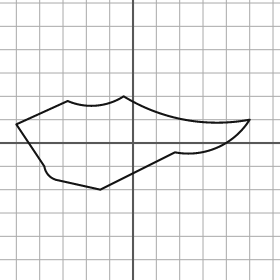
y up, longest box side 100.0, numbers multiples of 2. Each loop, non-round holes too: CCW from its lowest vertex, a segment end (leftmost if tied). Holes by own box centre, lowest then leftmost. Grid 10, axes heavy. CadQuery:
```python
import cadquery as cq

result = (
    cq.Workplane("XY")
    .moveTo(-14.0, -20.0)
    .lineTo(18.0, -4.0)
    .threePointArc((36.0, -2.0), (50.0, 10.0))
    .threePointArc((22.0, 10.0), (-4.0, 20.0))
    .threePointArc((-16.0, 16.0), (-28.0, 18.0))
    .lineTo(-50.0, 8.0)
    .lineTo(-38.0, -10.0)
    .threePointArc((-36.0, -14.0), (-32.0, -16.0))
    .close()
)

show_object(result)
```